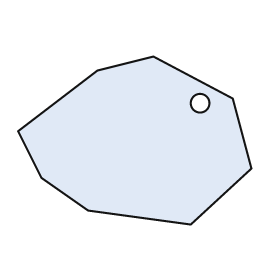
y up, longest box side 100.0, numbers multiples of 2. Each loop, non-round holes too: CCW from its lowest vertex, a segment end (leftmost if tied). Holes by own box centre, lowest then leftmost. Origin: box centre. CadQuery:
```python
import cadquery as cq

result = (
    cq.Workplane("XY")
    .moveTo(24.0, -36.0)
    .lineTo(50.0, -12.0)
    .lineTo(42.0, 18.0)
    .lineTo(8.0, 36.0)
    .lineTo(-16.0, 30.0)
    .lineTo(-50.0, 4.0)
    .lineTo(-40.0, -16.0)
    .lineTo(-20.0, -30.0)
    .close()
    .moveTo(28.0, 16.0)
    .circle(4.0)
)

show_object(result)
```